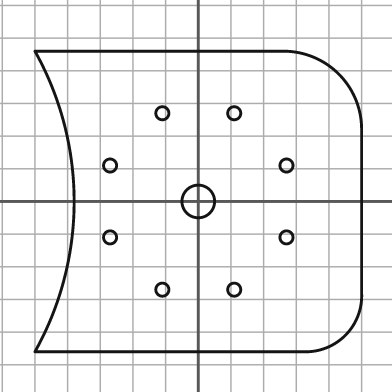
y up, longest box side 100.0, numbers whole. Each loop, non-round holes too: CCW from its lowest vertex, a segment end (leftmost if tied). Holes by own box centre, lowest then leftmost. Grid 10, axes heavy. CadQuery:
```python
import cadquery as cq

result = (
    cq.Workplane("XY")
    .moveTo(-50.0, -46.0)
    .lineTo(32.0, -46.0)
    .threePointArc((45.0, -41.0), (50.0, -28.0))
    .lineTo(50.0, 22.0)
    .threePointArc((43.0, 39.0), (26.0, 46.0))
    .lineTo(-50.0, 46.0)
    .threePointArc((-38.0, 0.0), (-50.0, -46.0))
    .close()
    .moveTo(-11.0, -27.0)
    .circle(2.0)
    .moveTo(11.0, -27.0)
    .circle(2.0)
    .moveTo(-27.0, -11.0)
    .circle(2.0)
    .moveTo(27.0, -11.0)
    .circle(2.0)
    .moveTo(0.0, 0.0)
    .circle(5.0)
    .moveTo(-27.0, 11.0)
    .circle(2.0)
    .moveTo(27.0, 11.0)
    .circle(2.0)
    .moveTo(-11.0, 27.0)
    .circle(2.0)
    .moveTo(11.0, 27.0)
    .circle(2.0)
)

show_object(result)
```